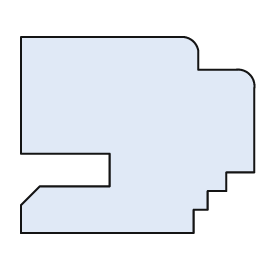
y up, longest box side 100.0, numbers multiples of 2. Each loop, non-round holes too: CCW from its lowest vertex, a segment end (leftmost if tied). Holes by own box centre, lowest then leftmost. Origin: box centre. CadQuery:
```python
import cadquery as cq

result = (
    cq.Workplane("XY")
    .moveTo(-50.0, -42.0)
    .lineTo(24.0, -42.0)
    .lineTo(24.0, -32.0)
    .lineTo(30.0, -32.0)
    .lineTo(30.0, -24.0)
    .lineTo(38.0, -24.0)
    .lineTo(38.0, -16.0)
    .lineTo(50.0, -16.0)
    .lineTo(50.0, 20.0)
    .threePointArc((48.0, 26.0), (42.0, 28.0))
    .lineTo(26.0, 28.0)
    .lineTo(26.0, 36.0)
    .threePointArc((24.0, 40.0), (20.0, 42.0))
    .lineTo(-50.0, 42.0)
    .lineTo(-50.0, -8.0)
    .lineTo(-12.0, -8.0)
    .lineTo(-12.0, -22.0)
    .lineTo(-42.0, -22.0)
    .lineTo(-50.0, -30.0)
    .close()
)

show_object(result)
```